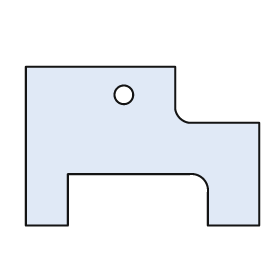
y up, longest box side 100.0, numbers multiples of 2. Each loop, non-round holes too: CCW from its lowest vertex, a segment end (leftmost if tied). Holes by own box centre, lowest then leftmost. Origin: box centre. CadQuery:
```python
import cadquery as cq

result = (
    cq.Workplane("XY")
    .moveTo(-50.0, -34.0)
    .lineTo(-32.0, -34.0)
    .lineTo(-32.0, -12.0)
    .lineTo(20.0, -12.0)
    .threePointArc((26.0, -14.0), (28.0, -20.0))
    .lineTo(28.0, -34.0)
    .lineTo(50.0, -34.0)
    .lineTo(50.0, 10.0)
    .lineTo(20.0, 10.0)
    .threePointArc((16.0, 12.0), (14.0, 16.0))
    .lineTo(14.0, 34.0)
    .lineTo(-50.0, 34.0)
    .close()
    .moveTo(-8.0, 22.0)
    .circle(4.0)
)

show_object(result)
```